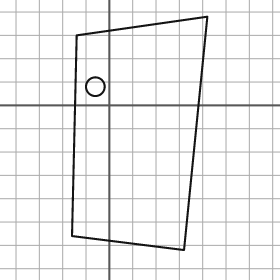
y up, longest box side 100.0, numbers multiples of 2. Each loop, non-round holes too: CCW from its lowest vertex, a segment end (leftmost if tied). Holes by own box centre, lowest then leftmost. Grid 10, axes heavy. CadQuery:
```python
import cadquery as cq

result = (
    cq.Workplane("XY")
    .moveTo(32.0, -62.0)
    .lineTo(42.0, 38.0)
    .lineTo(-14.0, 30.0)
    .lineTo(-16.0, -56.0)
    .close()
    .moveTo(-6.0, 8.0)
    .circle(4.0)
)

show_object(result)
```